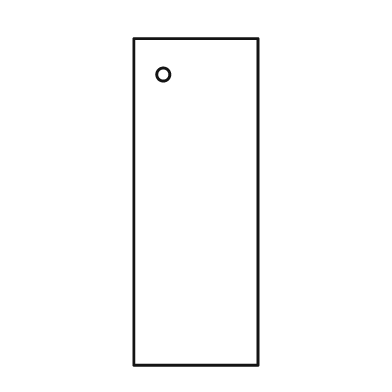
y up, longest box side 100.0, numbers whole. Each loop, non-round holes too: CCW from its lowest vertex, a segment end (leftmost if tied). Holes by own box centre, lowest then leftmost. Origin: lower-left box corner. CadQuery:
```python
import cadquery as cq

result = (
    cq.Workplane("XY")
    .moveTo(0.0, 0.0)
    .lineTo(38.0, 0.0)
    .lineTo(38.0, 100.0)
    .lineTo(0.0, 100.0)
    .close()
    .moveTo(9.0, 89.0)
    .circle(2.0)
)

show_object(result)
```